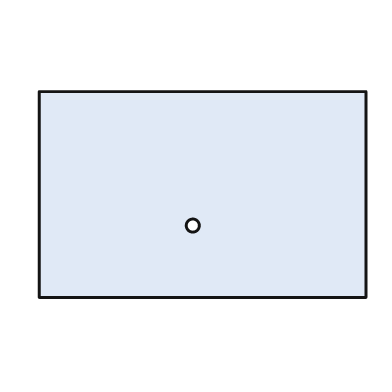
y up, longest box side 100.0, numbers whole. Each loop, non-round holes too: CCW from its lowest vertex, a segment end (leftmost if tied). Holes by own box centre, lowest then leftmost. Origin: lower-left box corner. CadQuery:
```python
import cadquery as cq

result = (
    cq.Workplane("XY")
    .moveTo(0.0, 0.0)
    .lineTo(100.0, 0.0)
    .lineTo(100.0, 63.0)
    .lineTo(0.0, 63.0)
    .close()
    .moveTo(47.0, 22.0)
    .circle(2.0)
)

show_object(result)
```